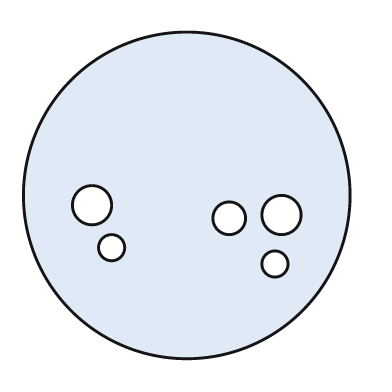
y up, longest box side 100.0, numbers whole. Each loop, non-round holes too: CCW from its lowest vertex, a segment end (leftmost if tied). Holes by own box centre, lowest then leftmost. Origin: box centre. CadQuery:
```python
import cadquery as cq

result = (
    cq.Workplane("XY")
    .moveTo(0.0, 0.0)
    .circle(50.0)
    .moveTo(27.0, -21.0)
    .circle(4.0)
    .moveTo(-23.0, -16.0)
    .circle(4.0)
    .moveTo(13.0, -7.0)
    .circle(5.0)
    .moveTo(29.0, -6.0)
    .circle(6.0)
    .moveTo(-29.0, -3.0)
    .circle(6.0)
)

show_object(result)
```